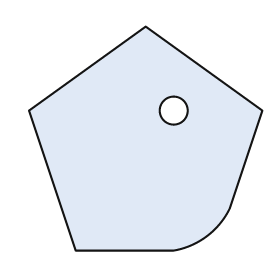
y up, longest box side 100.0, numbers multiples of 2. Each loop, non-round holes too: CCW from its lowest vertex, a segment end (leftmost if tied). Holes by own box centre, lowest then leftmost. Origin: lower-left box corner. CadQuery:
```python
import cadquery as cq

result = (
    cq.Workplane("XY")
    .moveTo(20.0, 0.0)
    .lineTo(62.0, 0.0)
    .threePointArc((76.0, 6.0), (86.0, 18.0))
    .lineTo(100.0, 60.0)
    .lineTo(50.0, 96.0)
    .lineTo(0.0, 60.0)
    .close()
    .moveTo(62.0, 60.0)
    .circle(6.0)
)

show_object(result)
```